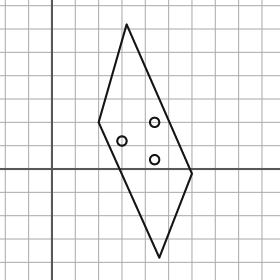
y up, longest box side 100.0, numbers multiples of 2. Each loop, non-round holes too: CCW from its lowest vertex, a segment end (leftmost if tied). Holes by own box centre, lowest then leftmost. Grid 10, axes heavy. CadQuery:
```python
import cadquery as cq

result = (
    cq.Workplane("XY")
    .moveTo(46.0, -38.0)
    .lineTo(60.0, -2.0)
    .lineTo(32.0, 62.0)
    .lineTo(20.0, 20.0)
    .close()
    .moveTo(44.0, 4.0)
    .circle(2.0)
    .moveTo(30.0, 12.0)
    .circle(2.0)
    .moveTo(44.0, 20.0)
    .circle(2.0)
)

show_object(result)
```